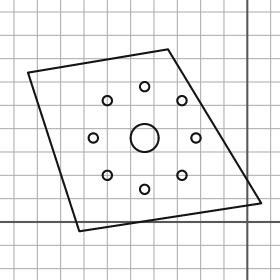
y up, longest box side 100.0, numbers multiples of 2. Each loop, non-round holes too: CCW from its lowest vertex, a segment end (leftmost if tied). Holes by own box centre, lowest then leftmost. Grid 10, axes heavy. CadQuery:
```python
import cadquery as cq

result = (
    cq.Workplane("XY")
    .moveTo(-72.0, -4.0)
    .lineTo(6.0, 8.0)
    .lineTo(-34.0, 74.0)
    .lineTo(-94.0, 64.0)
    .close()
    .moveTo(-44.0, 14.0)
    .circle(2.0)
    .moveTo(-60.0, 20.0)
    .circle(2.0)
    .moveTo(-28.0, 20.0)
    .circle(2.0)
    .moveTo(-66.0, 36.0)
    .circle(2.0)
    .moveTo(-44.0, 36.0)
    .circle(6.0)
    .moveTo(-22.0, 36.0)
    .circle(2.0)
    .moveTo(-60.0, 52.0)
    .circle(2.0)
    .moveTo(-28.0, 52.0)
    .circle(2.0)
    .moveTo(-44.0, 58.0)
    .circle(2.0)
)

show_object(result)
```